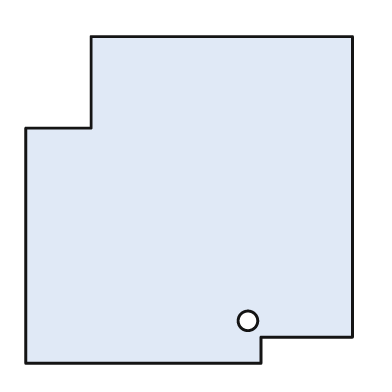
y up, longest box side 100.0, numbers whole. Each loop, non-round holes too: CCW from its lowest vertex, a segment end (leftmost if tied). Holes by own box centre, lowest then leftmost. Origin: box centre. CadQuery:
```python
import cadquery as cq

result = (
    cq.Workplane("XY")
    .moveTo(-50.0, -50.0)
    .lineTo(22.0, -50.0)
    .lineTo(22.0, -42.0)
    .lineTo(50.0, -42.0)
    .lineTo(50.0, 50.0)
    .lineTo(-30.0, 50.0)
    .lineTo(-30.0, 22.0)
    .lineTo(-50.0, 22.0)
    .close()
    .moveTo(18.0, -37.0)
    .circle(3.0)
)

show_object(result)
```